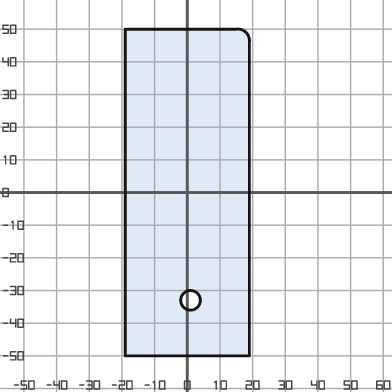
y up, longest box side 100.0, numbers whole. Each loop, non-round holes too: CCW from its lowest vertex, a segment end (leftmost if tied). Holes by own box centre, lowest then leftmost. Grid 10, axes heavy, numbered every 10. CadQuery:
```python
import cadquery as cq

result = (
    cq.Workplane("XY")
    .moveTo(-19.0, -50.0)
    .lineTo(19.0, -50.0)
    .lineTo(19.0, 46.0)
    .threePointArc((18.0, 49.0), (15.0, 50.0))
    .lineTo(-19.0, 50.0)
    .close()
    .moveTo(1.0, -33.0)
    .circle(3.0)
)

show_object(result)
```